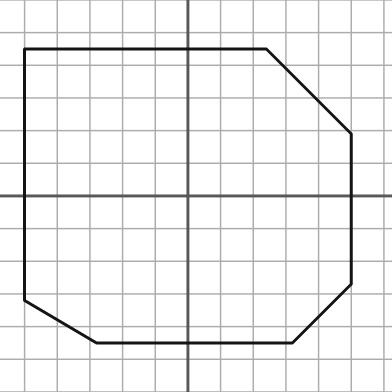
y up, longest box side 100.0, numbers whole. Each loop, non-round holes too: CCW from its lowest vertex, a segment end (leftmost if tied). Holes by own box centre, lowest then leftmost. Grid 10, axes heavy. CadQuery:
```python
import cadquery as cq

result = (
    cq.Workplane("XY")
    .moveTo(-28.0, -45.0)
    .lineTo(32.0, -45.0)
    .lineTo(50.0, -27.0)
    .lineTo(50.0, 19.0)
    .lineTo(24.0, 45.0)
    .lineTo(-50.0, 45.0)
    .lineTo(-50.0, -32.0)
    .close()
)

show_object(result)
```